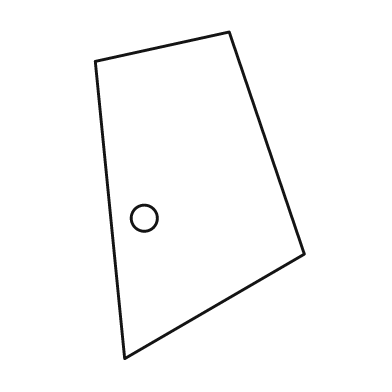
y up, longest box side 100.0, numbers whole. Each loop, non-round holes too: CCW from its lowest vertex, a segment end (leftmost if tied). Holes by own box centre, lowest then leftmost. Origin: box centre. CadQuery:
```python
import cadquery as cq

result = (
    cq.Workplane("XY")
    .moveTo(-23.0, -50.0)
    .lineTo(32.0, -18.0)
    .lineTo(9.0, 50.0)
    .lineTo(-32.0, 41.0)
    .close()
    .moveTo(-17.0, -7.0)
    .circle(4.0)
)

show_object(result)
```